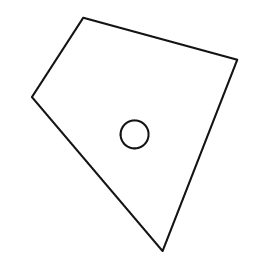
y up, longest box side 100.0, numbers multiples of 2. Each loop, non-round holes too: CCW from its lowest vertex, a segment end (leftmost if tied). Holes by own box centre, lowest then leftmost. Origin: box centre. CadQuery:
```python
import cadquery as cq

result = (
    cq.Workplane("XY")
    .moveTo(12.0, -50.0)
    .lineTo(44.0, 32.0)
    .lineTo(-22.0, 50.0)
    .lineTo(-44.0, 16.0)
    .close()
    .moveTo(0.0, 0.0)
    .circle(6.0)
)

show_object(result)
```